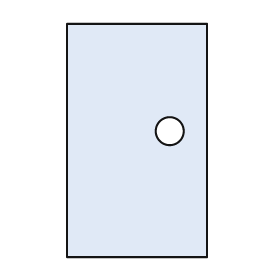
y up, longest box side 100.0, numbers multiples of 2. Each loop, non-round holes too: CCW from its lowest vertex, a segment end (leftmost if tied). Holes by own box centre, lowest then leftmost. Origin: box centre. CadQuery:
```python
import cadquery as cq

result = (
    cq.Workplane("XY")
    .moveTo(-30.0, -50.0)
    .lineTo(30.0, -50.0)
    .lineTo(30.0, 50.0)
    .lineTo(-30.0, 50.0)
    .close()
    .moveTo(14.0, 4.0)
    .circle(6.0)
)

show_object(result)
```